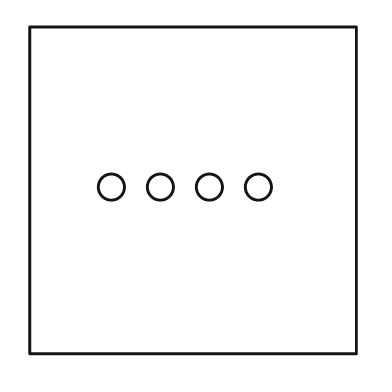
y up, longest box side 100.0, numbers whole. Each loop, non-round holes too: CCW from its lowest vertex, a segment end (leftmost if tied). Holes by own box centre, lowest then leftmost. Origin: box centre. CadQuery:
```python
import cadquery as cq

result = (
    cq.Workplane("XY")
    .moveTo(-50.0, -50.0)
    .lineTo(50.0, -50.0)
    .lineTo(50.0, 50.0)
    .lineTo(-50.0, 50.0)
    .close()
    .moveTo(-25.0, 1.0)
    .circle(4.0)
    .moveTo(-10.0, 1.0)
    .circle(4.0)
    .moveTo(5.0, 1.0)
    .circle(4.0)
    .moveTo(20.0, 1.0)
    .circle(4.0)
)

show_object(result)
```